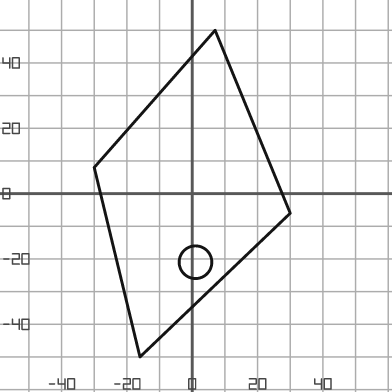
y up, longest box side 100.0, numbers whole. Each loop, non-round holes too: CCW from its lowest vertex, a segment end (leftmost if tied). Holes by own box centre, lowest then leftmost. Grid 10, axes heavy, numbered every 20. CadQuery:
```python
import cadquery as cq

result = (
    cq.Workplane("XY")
    .moveTo(-16.0, -50.0)
    .lineTo(30.0, -6.0)
    .lineTo(7.0, 50.0)
    .lineTo(-30.0, 8.0)
    .close()
    .moveTo(1.0, -21.0)
    .circle(5.0)
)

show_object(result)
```